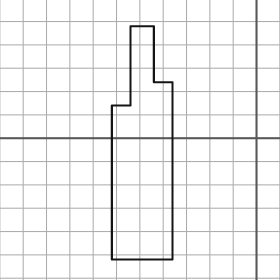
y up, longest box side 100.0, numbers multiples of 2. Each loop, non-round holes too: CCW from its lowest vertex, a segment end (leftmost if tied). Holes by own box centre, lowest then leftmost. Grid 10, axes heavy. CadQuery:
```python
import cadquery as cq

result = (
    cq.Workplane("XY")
    .moveTo(-62.0, -52.0)
    .lineTo(-36.0, -52.0)
    .lineTo(-36.0, 24.0)
    .lineTo(-44.0, 24.0)
    .lineTo(-44.0, 48.0)
    .lineTo(-54.0, 48.0)
    .lineTo(-54.0, 14.0)
    .lineTo(-62.0, 14.0)
    .close()
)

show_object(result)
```